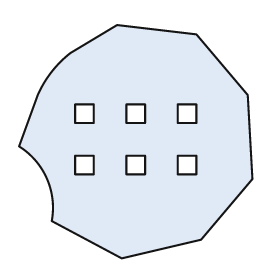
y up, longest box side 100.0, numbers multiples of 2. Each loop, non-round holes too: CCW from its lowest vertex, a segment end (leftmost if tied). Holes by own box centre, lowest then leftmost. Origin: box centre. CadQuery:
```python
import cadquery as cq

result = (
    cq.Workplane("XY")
    .moveTo(-6.0, -50.0)
    .lineTo(28.0, -42.0)
    .lineTo(50.0, -16.0)
    .lineTo(48.0, 20.0)
    .lineTo(26.0, 46.0)
    .lineTo(-8.0, 50.0)
    .lineTo(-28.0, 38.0)
    .threePointArc((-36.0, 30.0), (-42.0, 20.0))
    .lineTo(-50.0, -2.0)
    .threePointArc((-38.0, -16.0), (-36.0, -34.0))
    .close()
    .moveTo(-26.0, -14.0)
    .lineTo(-18.0, -14.0)
    .lineTo(-18.0, -6.0)
    .lineTo(-26.0, -6.0)
    .close()
    .moveTo(-4.0, -14.0)
    .lineTo(4.0, -14.0)
    .lineTo(4.0, -6.0)
    .lineTo(-4.0, -6.0)
    .close()
    .moveTo(18.0, -14.0)
    .lineTo(26.0, -14.0)
    .lineTo(26.0, -6.0)
    .lineTo(18.0, -6.0)
    .close()
    .moveTo(-26.0, 8.0)
    .lineTo(-18.0, 8.0)
    .lineTo(-18.0, 16.0)
    .lineTo(-26.0, 16.0)
    .close()
    .moveTo(-4.0, 8.0)
    .lineTo(4.0, 8.0)
    .lineTo(4.0, 16.0)
    .lineTo(-4.0, 16.0)
    .close()
    .moveTo(18.0, 8.0)
    .lineTo(26.0, 8.0)
    .lineTo(26.0, 16.0)
    .lineTo(18.0, 16.0)
    .close()
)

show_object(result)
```